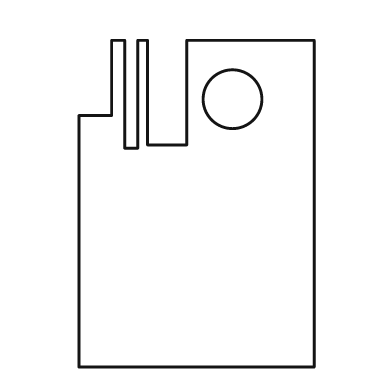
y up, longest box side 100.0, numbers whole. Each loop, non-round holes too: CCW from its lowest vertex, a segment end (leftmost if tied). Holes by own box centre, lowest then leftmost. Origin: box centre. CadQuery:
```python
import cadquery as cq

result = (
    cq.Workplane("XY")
    .moveTo(-36.0, -50.0)
    .lineTo(36.0, -50.0)
    .lineTo(36.0, 50.0)
    .lineTo(-3.0, 50.0)
    .lineTo(-3.0, 18.0)
    .lineTo(-15.0, 18.0)
    .lineTo(-15.0, 50.0)
    .lineTo(-18.0, 50.0)
    .lineTo(-18.0, 17.0)
    .lineTo(-22.0, 17.0)
    .lineTo(-22.0, 50.0)
    .lineTo(-26.0, 50.0)
    .lineTo(-26.0, 27.0)
    .lineTo(-36.0, 27.0)
    .close()
    .moveTo(11.0, 32.0)
    .circle(9.0)
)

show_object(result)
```